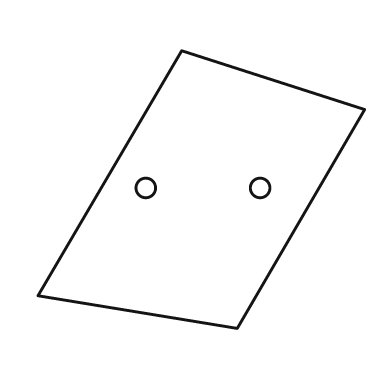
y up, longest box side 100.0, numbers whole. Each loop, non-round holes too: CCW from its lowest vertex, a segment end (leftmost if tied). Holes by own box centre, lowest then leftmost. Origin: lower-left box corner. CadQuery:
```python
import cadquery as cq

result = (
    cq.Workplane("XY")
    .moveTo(61.0, 0.0)
    .lineTo(100.0, 67.0)
    .lineTo(44.0, 85.0)
    .lineTo(0.0, 10.0)
    .close()
    .moveTo(33.0, 43.0)
    .circle(3.0)
    .moveTo(68.0, 43.0)
    .circle(3.0)
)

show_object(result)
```